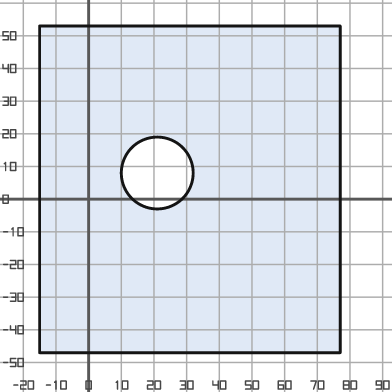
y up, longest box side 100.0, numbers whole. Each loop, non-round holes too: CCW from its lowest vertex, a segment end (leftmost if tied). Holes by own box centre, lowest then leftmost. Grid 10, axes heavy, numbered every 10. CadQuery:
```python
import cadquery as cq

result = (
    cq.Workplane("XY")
    .moveTo(-15.0, -47.0)
    .lineTo(77.0, -47.0)
    .lineTo(77.0, 53.0)
    .lineTo(-15.0, 53.0)
    .close()
    .moveTo(21.0, 8.0)
    .circle(11.0)
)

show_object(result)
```